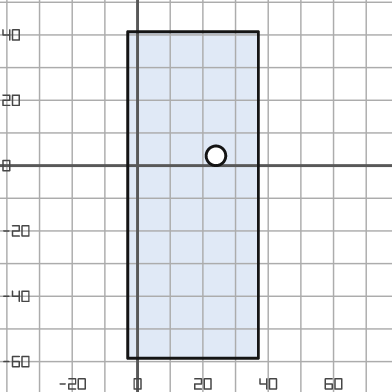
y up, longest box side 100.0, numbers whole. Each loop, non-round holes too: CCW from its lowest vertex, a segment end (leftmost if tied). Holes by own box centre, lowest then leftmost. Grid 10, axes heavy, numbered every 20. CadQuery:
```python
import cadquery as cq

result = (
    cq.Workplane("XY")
    .moveTo(-3.0, -59.0)
    .lineTo(37.0, -59.0)
    .lineTo(37.0, 41.0)
    .lineTo(-3.0, 41.0)
    .close()
    .moveTo(24.0, 3.0)
    .circle(3.0)
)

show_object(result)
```